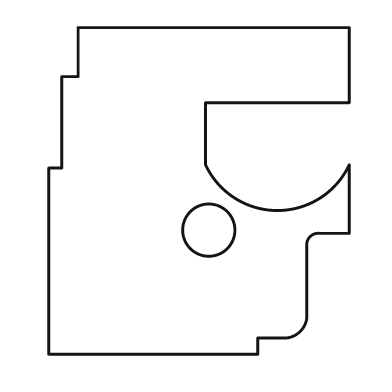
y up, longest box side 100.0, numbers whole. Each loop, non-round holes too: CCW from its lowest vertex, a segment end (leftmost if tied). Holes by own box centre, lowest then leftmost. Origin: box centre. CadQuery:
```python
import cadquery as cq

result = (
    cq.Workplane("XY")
    .moveTo(-46.0, -50.0)
    .lineTo(18.0, -50.0)
    .lineTo(18.0, -45.0)
    .lineTo(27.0, -45.0)
    .threePointArc((31.0, -43.0), (33.0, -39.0))
    .lineTo(33.0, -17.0)
    .threePointArc((34.0, -14.0), (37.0, -13.0))
    .lineTo(46.0, -13.0)
    .lineTo(46.0, 8.0)
    .threePointArc((24.0, -6.0), (2.0, 8.0))
    .lineTo(2.0, 27.0)
    .lineTo(46.0, 27.0)
    .lineTo(46.0, 50.0)
    .lineTo(-37.0, 50.0)
    .lineTo(-37.0, 35.0)
    .lineTo(-42.0, 35.0)
    .lineTo(-42.0, 7.0)
    .lineTo(-46.0, 7.0)
    .close()
    .moveTo(3.0, -12.0)
    .circle(8.0)
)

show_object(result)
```